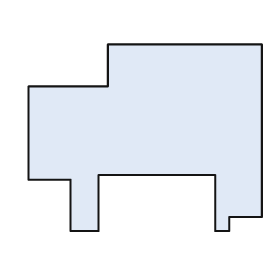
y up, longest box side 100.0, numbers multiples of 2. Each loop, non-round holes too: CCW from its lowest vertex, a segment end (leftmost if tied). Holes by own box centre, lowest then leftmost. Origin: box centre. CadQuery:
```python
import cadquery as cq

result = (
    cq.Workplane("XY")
    .moveTo(-32.0, -40.0)
    .lineTo(-20.0, -40.0)
    .lineTo(-20.0, -16.0)
    .lineTo(30.0, -16.0)
    .lineTo(30.0, -40.0)
    .lineTo(36.0, -40.0)
    .lineTo(36.0, -34.0)
    .lineTo(50.0, -34.0)
    .lineTo(50.0, 40.0)
    .lineTo(-16.0, 40.0)
    .lineTo(-16.0, 22.0)
    .lineTo(-50.0, 22.0)
    .lineTo(-50.0, -18.0)
    .lineTo(-32.0, -18.0)
    .close()
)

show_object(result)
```